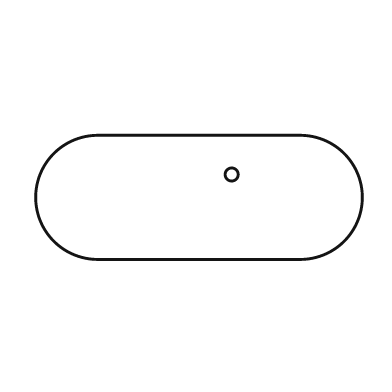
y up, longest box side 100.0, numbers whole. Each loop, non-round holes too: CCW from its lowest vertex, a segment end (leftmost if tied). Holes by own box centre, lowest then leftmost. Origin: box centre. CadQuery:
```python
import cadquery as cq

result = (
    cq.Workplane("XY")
    .moveTo(-31.0, -19.0)
    .lineTo(31.0, -19.0)
    .threePointArc((50.0, 0.0), (31.0, 19.0))
    .lineTo(-31.0, 19.0)
    .threePointArc((-50.0, 0.0), (-31.0, -19.0))
    .close()
    .moveTo(10.0, 7.0)
    .circle(2.0)
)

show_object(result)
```